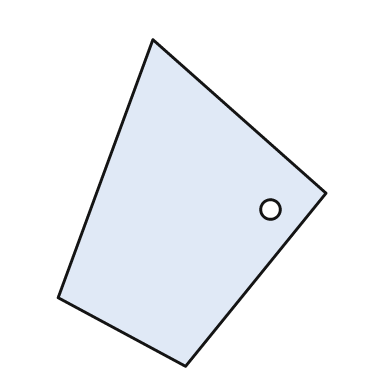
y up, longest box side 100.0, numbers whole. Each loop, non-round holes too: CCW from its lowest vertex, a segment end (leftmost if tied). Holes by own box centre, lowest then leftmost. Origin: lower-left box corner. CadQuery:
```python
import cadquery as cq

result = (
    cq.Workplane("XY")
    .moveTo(39.0, 0.0)
    .lineTo(82.0, 53.0)
    .lineTo(29.0, 100.0)
    .lineTo(0.0, 21.0)
    .close()
    .moveTo(65.0, 48.0)
    .circle(3.0)
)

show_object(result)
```